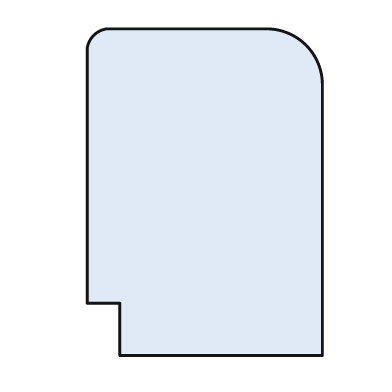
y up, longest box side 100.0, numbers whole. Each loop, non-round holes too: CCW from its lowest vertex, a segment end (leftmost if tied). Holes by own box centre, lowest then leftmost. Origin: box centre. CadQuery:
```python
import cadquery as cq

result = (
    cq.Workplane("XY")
    .moveTo(-26.0, -50.0)
    .lineTo(36.0, -50.0)
    .lineTo(36.0, 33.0)
    .threePointArc((31.0, 45.0), (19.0, 50.0))
    .lineTo(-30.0, 50.0)
    .threePointArc((-34.0, 48.0), (-36.0, 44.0))
    .lineTo(-36.0, -34.0)
    .lineTo(-26.0, -34.0)
    .close()
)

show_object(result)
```